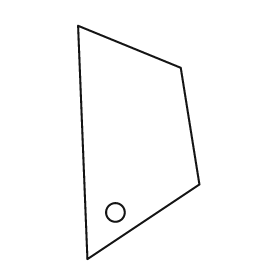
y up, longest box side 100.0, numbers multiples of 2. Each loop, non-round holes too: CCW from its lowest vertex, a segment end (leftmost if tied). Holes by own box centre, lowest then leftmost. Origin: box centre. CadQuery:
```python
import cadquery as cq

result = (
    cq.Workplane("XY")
    .moveTo(-22.0, -50.0)
    .lineTo(26.0, -18.0)
    .lineTo(18.0, 32.0)
    .lineTo(-26.0, 50.0)
    .close()
    .moveTo(-10.0, -30.0)
    .circle(4.0)
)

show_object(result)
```